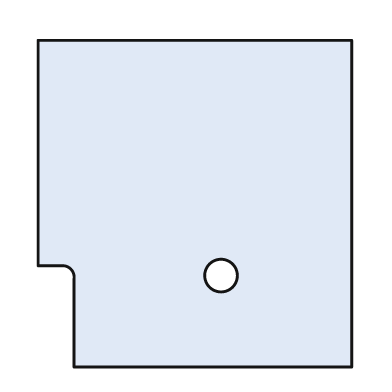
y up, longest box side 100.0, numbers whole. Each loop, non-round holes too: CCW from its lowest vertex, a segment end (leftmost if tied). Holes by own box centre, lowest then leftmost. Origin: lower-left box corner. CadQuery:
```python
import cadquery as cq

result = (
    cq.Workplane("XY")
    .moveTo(11.0, 0.0)
    .lineTo(96.0, 0.0)
    .lineTo(96.0, 100.0)
    .lineTo(0.0, 100.0)
    .lineTo(0.0, 31.0)
    .lineTo(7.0, 31.0)
    .threePointArc((10.0, 30.0), (11.0, 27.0))
    .close()
    .moveTo(56.0, 28.0)
    .circle(5.0)
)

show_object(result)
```